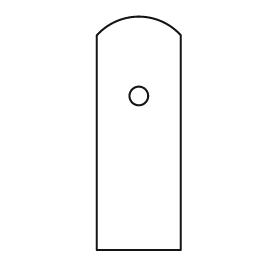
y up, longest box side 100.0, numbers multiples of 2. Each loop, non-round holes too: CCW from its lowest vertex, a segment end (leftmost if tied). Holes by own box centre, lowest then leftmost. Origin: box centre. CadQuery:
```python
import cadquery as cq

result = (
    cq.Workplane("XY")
    .moveTo(-18.0, -50.0)
    .lineTo(18.0, -50.0)
    .lineTo(18.0, 42.0)
    .threePointArc((0.0, 50.0), (-18.0, 42.0))
    .close()
    .moveTo(0.0, 16.0)
    .circle(4.0)
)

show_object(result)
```